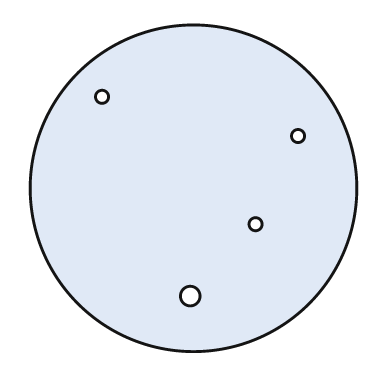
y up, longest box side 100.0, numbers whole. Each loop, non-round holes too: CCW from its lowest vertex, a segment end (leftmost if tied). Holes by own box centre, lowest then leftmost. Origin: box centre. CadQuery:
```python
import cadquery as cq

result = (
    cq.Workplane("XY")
    .moveTo(0.0, 0.0)
    .circle(50.0)
    .moveTo(-1.0, -33.0)
    .circle(3.0)
    .moveTo(19.0, -11.0)
    .circle(2.0)
    .moveTo(32.0, 16.0)
    .circle(2.0)
    .moveTo(-28.0, 28.0)
    .circle(2.0)
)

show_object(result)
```